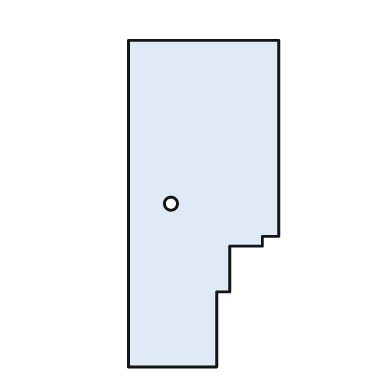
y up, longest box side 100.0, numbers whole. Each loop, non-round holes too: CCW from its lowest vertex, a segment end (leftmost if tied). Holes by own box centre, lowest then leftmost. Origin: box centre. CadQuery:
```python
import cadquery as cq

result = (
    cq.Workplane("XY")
    .moveTo(-23.0, -50.0)
    .lineTo(4.0, -50.0)
    .lineTo(4.0, -27.0)
    .lineTo(8.0, -27.0)
    .lineTo(8.0, -13.0)
    .lineTo(18.0, -13.0)
    .lineTo(18.0, -10.0)
    .lineTo(23.0, -10.0)
    .lineTo(23.0, 50.0)
    .lineTo(-23.0, 50.0)
    .close()
    .moveTo(-10.0, 0.0)
    .circle(2.0)
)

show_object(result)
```